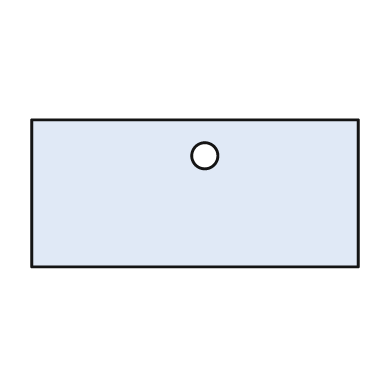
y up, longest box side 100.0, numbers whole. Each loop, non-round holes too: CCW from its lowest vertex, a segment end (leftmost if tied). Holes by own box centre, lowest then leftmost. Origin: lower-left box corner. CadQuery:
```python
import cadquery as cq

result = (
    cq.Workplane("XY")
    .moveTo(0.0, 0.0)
    .lineTo(100.0, 0.0)
    .lineTo(100.0, 45.0)
    .lineTo(0.0, 45.0)
    .close()
    .moveTo(53.0, 34.0)
    .circle(4.0)
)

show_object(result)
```